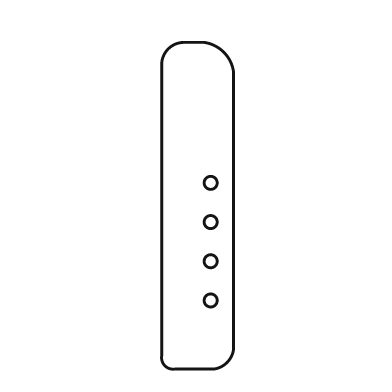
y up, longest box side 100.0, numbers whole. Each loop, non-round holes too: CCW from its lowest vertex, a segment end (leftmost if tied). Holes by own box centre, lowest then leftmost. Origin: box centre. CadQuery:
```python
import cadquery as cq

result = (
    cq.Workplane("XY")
    .moveTo(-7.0, -50.0)
    .lineTo(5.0, -50.0)
    .threePointArc((9.0, -48.0), (11.0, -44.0))
    .lineTo(11.0, 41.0)
    .threePointArc((8.0, 47.0), (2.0, 50.0))
    .lineTo(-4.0, 50.0)
    .threePointArc((-9.0, 48.0), (-11.0, 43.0))
    .lineTo(-11.0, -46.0)
    .threePointArc((-10.0, -49.0), (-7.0, -50.0))
    .close()
    .moveTo(4.0, -29.0)
    .circle(2.0)
    .moveTo(4.0, -17.0)
    .circle(2.0)
    .moveTo(4.0, -5.0)
    .circle(2.0)
    .moveTo(4.0, 7.0)
    .circle(2.0)
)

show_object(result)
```